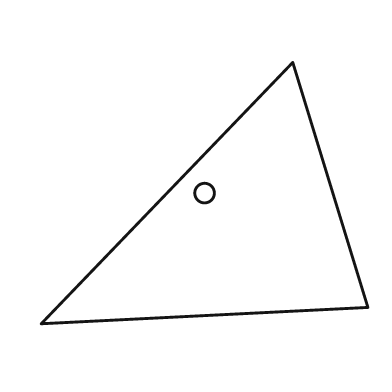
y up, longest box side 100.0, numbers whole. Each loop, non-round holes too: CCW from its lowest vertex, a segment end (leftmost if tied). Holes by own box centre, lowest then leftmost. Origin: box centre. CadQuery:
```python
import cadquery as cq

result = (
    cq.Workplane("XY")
    .moveTo(-50.0, -40.0)
    .lineTo(50.0, -35.0)
    .lineTo(27.0, 40.0)
    .close()
    .moveTo(0.0, 0.0)
    .circle(3.0)
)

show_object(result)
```